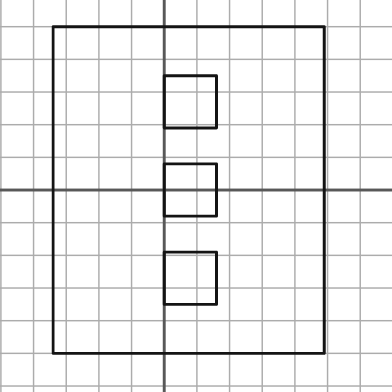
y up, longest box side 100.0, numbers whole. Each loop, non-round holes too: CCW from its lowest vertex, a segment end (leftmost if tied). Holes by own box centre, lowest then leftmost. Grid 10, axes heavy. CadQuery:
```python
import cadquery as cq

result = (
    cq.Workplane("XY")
    .moveTo(-34.0, -50.0)
    .lineTo(49.0, -50.0)
    .lineTo(49.0, 50.0)
    .lineTo(-34.0, 50.0)
    .close()
    .moveTo(0.0, -35.0)
    .lineTo(16.0, -35.0)
    .lineTo(16.0, -19.0)
    .lineTo(0.0, -19.0)
    .close()
    .moveTo(0.0, -8.0)
    .lineTo(16.0, -8.0)
    .lineTo(16.0, 8.0)
    .lineTo(0.0, 8.0)
    .close()
    .moveTo(0.0, 19.0)
    .lineTo(16.0, 19.0)
    .lineTo(16.0, 35.0)
    .lineTo(0.0, 35.0)
    .close()
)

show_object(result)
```